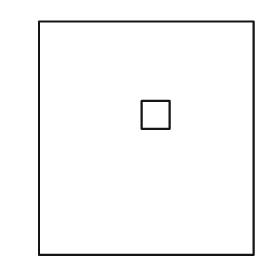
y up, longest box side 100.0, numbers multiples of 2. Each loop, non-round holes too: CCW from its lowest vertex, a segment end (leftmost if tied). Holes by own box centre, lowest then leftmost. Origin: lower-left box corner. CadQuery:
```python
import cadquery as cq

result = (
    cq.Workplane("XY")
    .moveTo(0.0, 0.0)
    .lineTo(92.0, 0.0)
    .lineTo(92.0, 100.0)
    .lineTo(0.0, 100.0)
    .close()
    .moveTo(44.0, 54.0)
    .lineTo(56.0, 54.0)
    .lineTo(56.0, 66.0)
    .lineTo(44.0, 66.0)
    .close()
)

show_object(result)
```